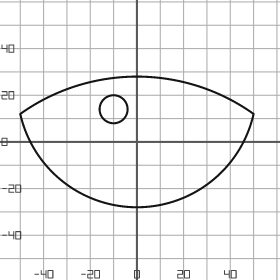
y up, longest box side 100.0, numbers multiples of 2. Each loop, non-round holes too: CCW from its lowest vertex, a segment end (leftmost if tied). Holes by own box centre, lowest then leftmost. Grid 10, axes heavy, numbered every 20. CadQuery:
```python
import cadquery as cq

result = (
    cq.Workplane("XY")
    .moveTo(-50.0, 12.0)
    .threePointArc((0.0, -28.0), (50.0, 12.0))
    .threePointArc((0.0, 28.0), (-50.0, 12.0))
    .close()
    .moveTo(-10.0, 14.0)
    .circle(6.0)
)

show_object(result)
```